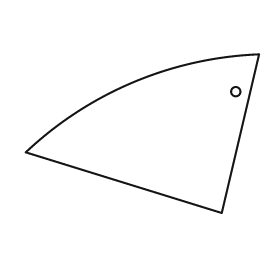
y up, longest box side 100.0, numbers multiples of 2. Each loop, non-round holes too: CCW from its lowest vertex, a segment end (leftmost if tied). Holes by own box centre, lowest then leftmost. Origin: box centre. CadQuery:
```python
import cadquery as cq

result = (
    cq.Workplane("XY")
    .moveTo(34.0, -34.0)
    .lineTo(50.0, 34.0)
    .threePointArc((-4.0, 22.0), (-50.0, -8.0))
    .close()
    .moveTo(40.0, 18.0)
    .circle(2.0)
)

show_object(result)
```